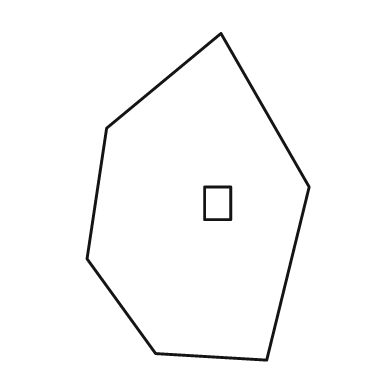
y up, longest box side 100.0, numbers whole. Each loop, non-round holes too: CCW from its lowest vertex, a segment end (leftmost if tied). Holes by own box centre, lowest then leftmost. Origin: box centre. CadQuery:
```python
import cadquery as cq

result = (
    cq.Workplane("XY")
    .moveTo(21.0, -50.0)
    .lineTo(34.0, 3.0)
    .lineTo(7.0, 50.0)
    .lineTo(-28.0, 21.0)
    .lineTo(-34.0, -19.0)
    .lineTo(-13.0, -48.0)
    .close()
    .moveTo(2.0, -7.0)
    .lineTo(10.0, -7.0)
    .lineTo(10.0, 3.0)
    .lineTo(2.0, 3.0)
    .close()
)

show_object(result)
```